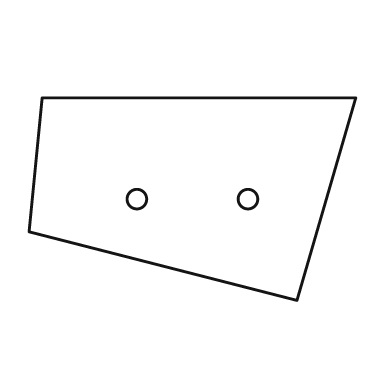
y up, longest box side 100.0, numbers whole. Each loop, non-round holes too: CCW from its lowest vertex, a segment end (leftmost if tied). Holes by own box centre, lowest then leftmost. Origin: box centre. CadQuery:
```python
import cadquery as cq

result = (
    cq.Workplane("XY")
    .moveTo(32.0, -31.0)
    .lineTo(50.0, 31.0)
    .lineTo(-46.0, 31.0)
    .lineTo(-50.0, -10.0)
    .close()
    .moveTo(-17.0, 0.0)
    .circle(3.0)
    .moveTo(17.0, 0.0)
    .circle(3.0)
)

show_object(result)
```